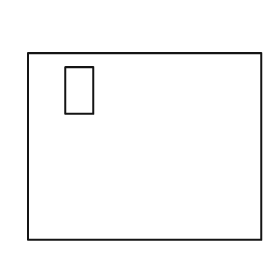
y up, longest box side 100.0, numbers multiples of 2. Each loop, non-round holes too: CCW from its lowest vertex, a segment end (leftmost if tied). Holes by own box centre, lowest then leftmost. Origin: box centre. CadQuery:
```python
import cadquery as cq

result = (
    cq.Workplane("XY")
    .moveTo(-50.0, -40.0)
    .lineTo(50.0, -40.0)
    .lineTo(50.0, 40.0)
    .lineTo(-50.0, 40.0)
    .close()
    .moveTo(-34.0, 14.0)
    .lineTo(-22.0, 14.0)
    .lineTo(-22.0, 34.0)
    .lineTo(-34.0, 34.0)
    .close()
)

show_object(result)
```